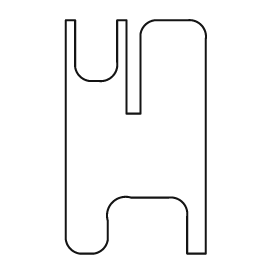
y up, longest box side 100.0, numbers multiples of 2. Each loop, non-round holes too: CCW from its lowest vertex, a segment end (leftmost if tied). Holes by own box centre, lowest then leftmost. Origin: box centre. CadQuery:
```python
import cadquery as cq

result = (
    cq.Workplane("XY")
    .moveTo(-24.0, -50.0)
    .lineTo(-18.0, -50.0)
    .threePointArc((-14.0, -48.0), (-12.0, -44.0))
    .lineTo(-12.0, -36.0)
    .threePointArc((-10.0, -28.0), (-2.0, -26.0))
    .lineTo(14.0, -26.0)
    .threePointArc((20.0, -28.0), (22.0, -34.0))
    .lineTo(22.0, -50.0)
    .lineTo(30.0, -50.0)
    .lineTo(30.0, 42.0)
    .threePointArc((28.0, 48.0), (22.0, 50.0))
    .lineTo(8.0, 50.0)
    .threePointArc((4.0, 48.0), (2.0, 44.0))
    .lineTo(2.0, 10.0)
    .lineTo(-4.0, 10.0)
    .lineTo(-4.0, 50.0)
    .lineTo(-8.0, 50.0)
    .lineTo(-8.0, 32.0)
    .threePointArc((-10.0, 26.0), (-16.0, 24.0))
    .lineTo(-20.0, 24.0)
    .threePointArc((-24.0, 26.0), (-26.0, 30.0))
    .lineTo(-26.0, 50.0)
    .lineTo(-30.0, 50.0)
    .lineTo(-30.0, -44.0)
    .threePointArc((-28.0, -48.0), (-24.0, -50.0))
    .close()
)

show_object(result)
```